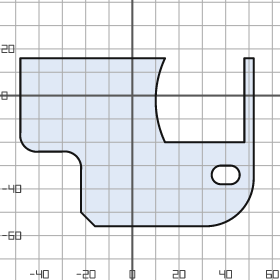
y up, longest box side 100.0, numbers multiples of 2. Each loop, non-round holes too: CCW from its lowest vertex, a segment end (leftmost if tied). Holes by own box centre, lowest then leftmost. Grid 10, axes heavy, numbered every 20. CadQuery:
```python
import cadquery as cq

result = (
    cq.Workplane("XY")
    .moveTo(-16.0, -56.0)
    .lineTo(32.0, -56.0)
    .threePointArc((46.0, -50.0), (52.0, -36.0))
    .lineTo(52.0, 16.0)
    .lineTo(48.0, 16.0)
    .lineTo(48.0, -20.0)
    .lineTo(14.0, -20.0)
    .threePointArc((10.0, -2.0), (14.0, 16.0))
    .lineTo(-48.0, 16.0)
    .lineTo(-48.0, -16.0)
    .threePointArc((-46.0, -22.0), (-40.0, -24.0))
    .lineTo(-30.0, -24.0)
    .threePointArc((-24.0, -26.0), (-22.0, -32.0))
    .lineTo(-22.0, -50.0)
    .close()
    .moveTo(38.0, -38.0)
    .lineTo(42.0, -38.0)
    .threePointArc((46.0, -34.0), (42.0, -30.0))
    .lineTo(38.0, -30.0)
    .threePointArc((34.0, -34.0), (38.0, -38.0))
    .close()
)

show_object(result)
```